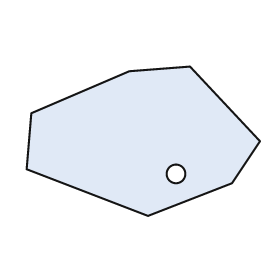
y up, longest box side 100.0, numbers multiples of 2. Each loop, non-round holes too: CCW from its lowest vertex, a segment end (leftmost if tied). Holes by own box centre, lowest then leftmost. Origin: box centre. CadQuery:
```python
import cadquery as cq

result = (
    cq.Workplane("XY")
    .moveTo(2.0, -32.0)
    .lineTo(38.0, -18.0)
    .lineTo(50.0, 0.0)
    .lineTo(20.0, 32.0)
    .lineTo(-6.0, 30.0)
    .lineTo(-48.0, 12.0)
    .lineTo(-50.0, -12.0)
    .close()
    .moveTo(14.0, -14.0)
    .circle(4.0)
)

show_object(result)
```